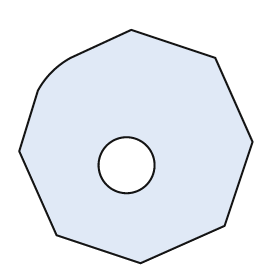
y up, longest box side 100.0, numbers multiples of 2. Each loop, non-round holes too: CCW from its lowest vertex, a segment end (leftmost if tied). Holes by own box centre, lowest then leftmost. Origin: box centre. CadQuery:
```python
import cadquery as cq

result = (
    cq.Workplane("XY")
    .moveTo(2.0, -50.0)
    .lineTo(38.0, -34.0)
    .lineTo(50.0, 2.0)
    .lineTo(34.0, 38.0)
    .lineTo(-2.0, 50.0)
    .lineTo(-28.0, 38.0)
    .threePointArc((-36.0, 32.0), (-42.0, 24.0))
    .lineTo(-50.0, -2.0)
    .lineTo(-34.0, -38.0)
    .close()
    .moveTo(-4.0, -8.0)
    .circle(12.0)
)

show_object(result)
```